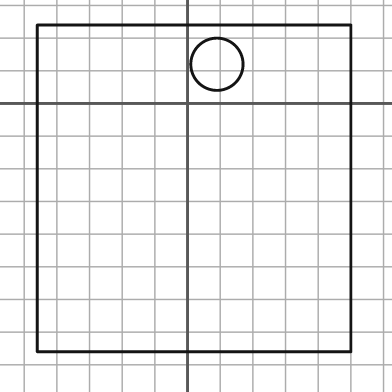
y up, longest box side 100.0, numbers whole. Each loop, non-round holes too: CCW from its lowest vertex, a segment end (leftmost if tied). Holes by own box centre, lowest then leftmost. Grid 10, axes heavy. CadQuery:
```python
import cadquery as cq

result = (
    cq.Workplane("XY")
    .moveTo(-46.0, -76.0)
    .lineTo(50.0, -76.0)
    .lineTo(50.0, 24.0)
    .lineTo(-46.0, 24.0)
    .close()
    .moveTo(9.0, 12.0)
    .circle(8.0)
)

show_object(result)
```